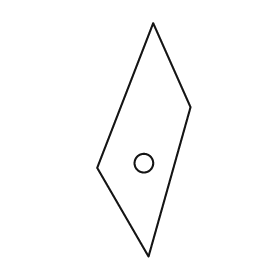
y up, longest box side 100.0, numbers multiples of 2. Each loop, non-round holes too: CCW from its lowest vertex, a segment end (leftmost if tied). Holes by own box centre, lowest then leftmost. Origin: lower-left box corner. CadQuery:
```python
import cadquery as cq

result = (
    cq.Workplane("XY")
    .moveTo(22.0, 0.0)
    .lineTo(40.0, 64.0)
    .lineTo(24.0, 100.0)
    .lineTo(0.0, 38.0)
    .close()
    .moveTo(20.0, 40.0)
    .circle(4.0)
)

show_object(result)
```